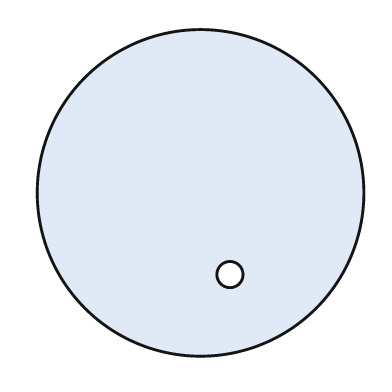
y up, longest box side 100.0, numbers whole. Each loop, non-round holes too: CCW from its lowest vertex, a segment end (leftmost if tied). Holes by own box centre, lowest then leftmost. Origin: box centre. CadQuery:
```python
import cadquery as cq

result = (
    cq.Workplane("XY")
    .moveTo(0.0, 0.0)
    .circle(50.0)
    .moveTo(9.0, -25.0)
    .circle(4.0)
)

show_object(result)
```